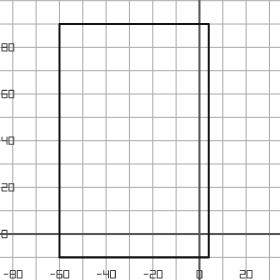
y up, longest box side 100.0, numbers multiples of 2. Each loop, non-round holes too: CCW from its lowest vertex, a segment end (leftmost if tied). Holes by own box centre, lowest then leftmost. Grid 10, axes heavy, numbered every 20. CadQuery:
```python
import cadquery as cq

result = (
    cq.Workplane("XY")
    .moveTo(-60.0, -10.0)
    .lineTo(4.0, -10.0)
    .lineTo(4.0, 90.0)
    .lineTo(-60.0, 90.0)
    .close()
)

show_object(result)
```